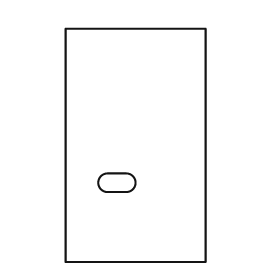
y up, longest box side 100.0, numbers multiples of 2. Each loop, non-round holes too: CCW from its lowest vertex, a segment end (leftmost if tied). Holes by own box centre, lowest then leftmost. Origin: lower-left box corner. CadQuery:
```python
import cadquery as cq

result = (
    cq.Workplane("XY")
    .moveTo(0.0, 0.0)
    .lineTo(60.0, 0.0)
    .lineTo(60.0, 100.0)
    .lineTo(0.0, 100.0)
    .close()
    .moveTo(18.0, 30.0)
    .lineTo(26.0, 30.0)
    .threePointArc((30.0, 34.0), (26.0, 38.0))
    .lineTo(18.0, 38.0)
    .threePointArc((14.0, 34.0), (18.0, 30.0))
    .close()
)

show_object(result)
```